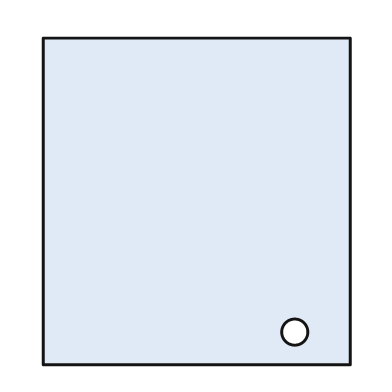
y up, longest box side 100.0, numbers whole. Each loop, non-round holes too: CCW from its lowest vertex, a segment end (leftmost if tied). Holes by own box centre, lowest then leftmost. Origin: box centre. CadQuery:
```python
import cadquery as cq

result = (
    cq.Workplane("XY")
    .moveTo(-47.0, -50.0)
    .lineTo(47.0, -50.0)
    .lineTo(47.0, 50.0)
    .lineTo(-47.0, 50.0)
    .close()
    .moveTo(30.0, -40.0)
    .circle(4.0)
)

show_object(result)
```